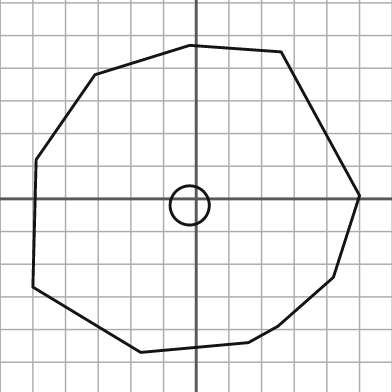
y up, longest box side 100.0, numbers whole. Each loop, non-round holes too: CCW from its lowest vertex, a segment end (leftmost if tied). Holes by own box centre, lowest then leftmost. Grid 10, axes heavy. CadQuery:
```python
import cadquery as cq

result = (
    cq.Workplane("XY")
    .moveTo(-17.0, -47.0)
    .lineTo(16.0, -44.0)
    .lineTo(25.0, -39.0)
    .lineTo(42.0, -24.0)
    .lineTo(50.0, 1.0)
    .lineTo(26.0, 45.0)
    .lineTo(-2.0, 47.0)
    .lineTo(-31.0, 38.0)
    .lineTo(-49.0, 12.0)
    .lineTo(-50.0, -27.0)
    .close()
    .moveTo(-2.0, -2.0)
    .circle(6.0)
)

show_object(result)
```